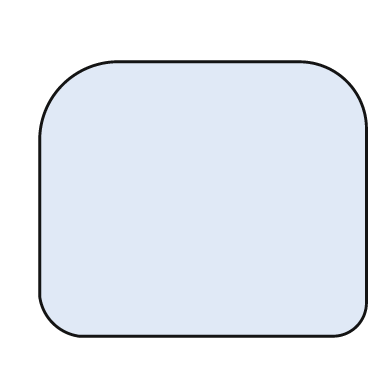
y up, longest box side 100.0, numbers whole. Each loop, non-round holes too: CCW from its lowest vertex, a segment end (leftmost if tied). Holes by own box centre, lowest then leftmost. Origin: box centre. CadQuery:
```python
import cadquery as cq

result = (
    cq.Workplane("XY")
    .moveTo(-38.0, -42.0)
    .lineTo(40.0, -42.0)
    .threePointArc((47.0, -39.0), (50.0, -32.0))
    .lineTo(50.0, 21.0)
    .threePointArc((44.0, 36.0), (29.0, 42.0))
    .lineTo(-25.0, 42.0)
    .threePointArc((-43.0, 35.0), (-50.0, 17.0))
    .lineTo(-50.0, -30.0)
    .threePointArc((-46.0, -38.0), (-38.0, -42.0))
    .close()
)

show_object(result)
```